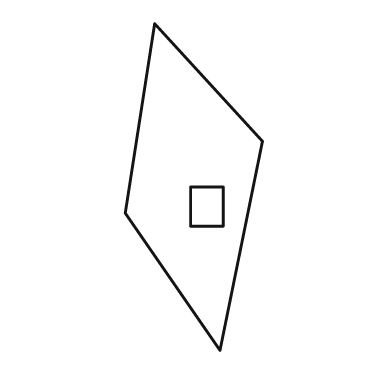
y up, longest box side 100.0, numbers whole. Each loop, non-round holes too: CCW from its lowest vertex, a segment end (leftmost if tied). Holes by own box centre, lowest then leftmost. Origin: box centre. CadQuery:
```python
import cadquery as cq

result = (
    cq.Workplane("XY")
    .moveTo(8.0, -50.0)
    .lineTo(21.0, 14.0)
    .lineTo(-12.0, 50.0)
    .lineTo(-21.0, -8.0)
    .close()
    .moveTo(-1.0, -12.0)
    .lineTo(9.0, -12.0)
    .lineTo(9.0, 0.0)
    .lineTo(-1.0, 0.0)
    .close()
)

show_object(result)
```